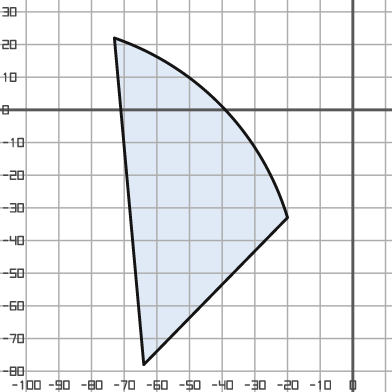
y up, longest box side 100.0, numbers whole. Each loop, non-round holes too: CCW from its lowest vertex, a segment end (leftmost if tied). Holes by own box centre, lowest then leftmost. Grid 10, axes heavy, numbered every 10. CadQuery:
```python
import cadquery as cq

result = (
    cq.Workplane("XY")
    .moveTo(-64.0, -78.0)
    .lineTo(-20.0, -33.0)
    .threePointArc((-40.0, 1.0), (-73.0, 22.0))
    .close()
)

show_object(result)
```